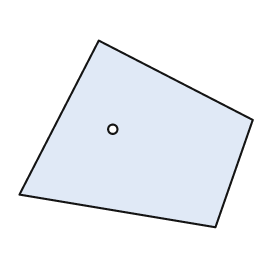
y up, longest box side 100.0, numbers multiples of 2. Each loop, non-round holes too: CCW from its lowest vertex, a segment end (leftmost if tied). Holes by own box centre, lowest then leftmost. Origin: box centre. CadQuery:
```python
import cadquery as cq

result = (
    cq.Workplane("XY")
    .moveTo(34.0, -40.0)
    .lineTo(50.0, 6.0)
    .lineTo(-16.0, 40.0)
    .lineTo(-50.0, -26.0)
    .close()
    .moveTo(-10.0, 2.0)
    .circle(2.0)
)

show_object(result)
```